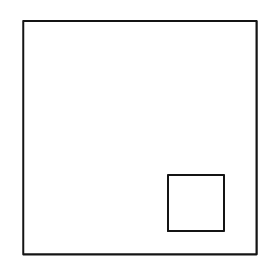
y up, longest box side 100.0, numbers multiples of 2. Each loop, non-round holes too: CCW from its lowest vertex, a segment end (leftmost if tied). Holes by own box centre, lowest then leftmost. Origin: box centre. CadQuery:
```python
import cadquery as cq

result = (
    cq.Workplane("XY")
    .moveTo(-50.0, -50.0)
    .lineTo(50.0, -50.0)
    .lineTo(50.0, 50.0)
    .lineTo(-50.0, 50.0)
    .close()
    .moveTo(12.0, -40.0)
    .lineTo(36.0, -40.0)
    .lineTo(36.0, -16.0)
    .lineTo(12.0, -16.0)
    .close()
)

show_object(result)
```